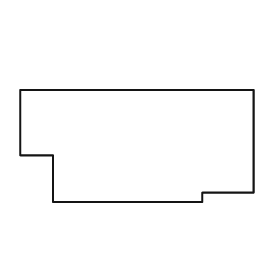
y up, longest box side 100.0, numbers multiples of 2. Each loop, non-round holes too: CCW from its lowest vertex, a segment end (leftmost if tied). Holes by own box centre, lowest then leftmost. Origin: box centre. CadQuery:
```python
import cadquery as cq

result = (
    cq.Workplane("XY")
    .moveTo(-36.0, -24.0)
    .lineTo(28.0, -24.0)
    .lineTo(28.0, -20.0)
    .lineTo(50.0, -20.0)
    .lineTo(50.0, 24.0)
    .lineTo(-50.0, 24.0)
    .lineTo(-50.0, -4.0)
    .lineTo(-36.0, -4.0)
    .close()
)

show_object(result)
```